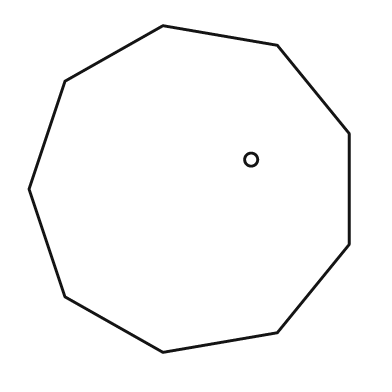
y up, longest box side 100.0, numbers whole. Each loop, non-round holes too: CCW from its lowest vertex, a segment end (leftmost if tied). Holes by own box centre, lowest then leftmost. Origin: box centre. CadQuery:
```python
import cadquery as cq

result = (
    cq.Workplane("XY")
    .moveTo(-8.0, -50.0)
    .lineTo(27.0, -44.0)
    .lineTo(49.0, -17.0)
    .lineTo(49.0, 17.0)
    .lineTo(27.0, 44.0)
    .lineTo(-8.0, 50.0)
    .lineTo(-38.0, 33.0)
    .lineTo(-49.0, 0.0)
    .lineTo(-38.0, -33.0)
    .close()
    .moveTo(19.0, 9.0)
    .circle(2.0)
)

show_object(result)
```